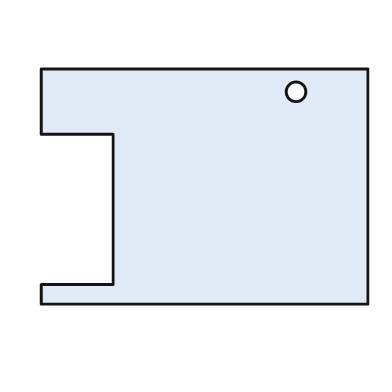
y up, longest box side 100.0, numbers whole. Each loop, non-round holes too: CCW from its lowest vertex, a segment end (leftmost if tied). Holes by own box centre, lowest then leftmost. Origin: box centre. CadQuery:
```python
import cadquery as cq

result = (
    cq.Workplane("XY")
    .moveTo(-50.0, -36.0)
    .lineTo(50.0, -36.0)
    .lineTo(50.0, 36.0)
    .lineTo(-50.0, 36.0)
    .lineTo(-50.0, 16.0)
    .lineTo(-28.0, 16.0)
    .lineTo(-28.0, -30.0)
    .lineTo(-50.0, -30.0)
    .close()
    .moveTo(28.0, 29.0)
    .circle(3.0)
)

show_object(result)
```